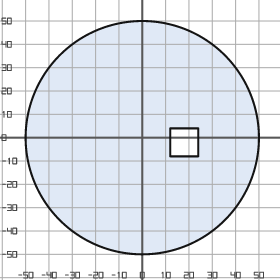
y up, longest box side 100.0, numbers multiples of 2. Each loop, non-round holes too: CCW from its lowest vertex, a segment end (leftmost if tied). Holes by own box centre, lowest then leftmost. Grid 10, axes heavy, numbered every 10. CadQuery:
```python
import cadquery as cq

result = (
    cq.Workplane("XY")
    .moveTo(0.0, 0.0)
    .circle(50.0)
    .moveTo(12.0, -8.0)
    .lineTo(24.0, -8.0)
    .lineTo(24.0, 4.0)
    .lineTo(12.0, 4.0)
    .close()
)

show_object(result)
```